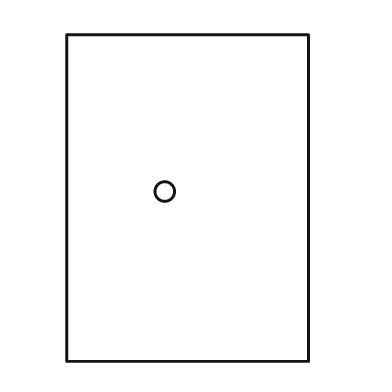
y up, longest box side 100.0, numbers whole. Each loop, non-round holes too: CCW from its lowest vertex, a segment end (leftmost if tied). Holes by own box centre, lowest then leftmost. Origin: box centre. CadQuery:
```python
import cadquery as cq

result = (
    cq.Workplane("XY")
    .moveTo(-37.0, -50.0)
    .lineTo(37.0, -50.0)
    .lineTo(37.0, 50.0)
    .lineTo(-37.0, 50.0)
    .close()
    .moveTo(-7.0, 2.0)
    .circle(3.0)
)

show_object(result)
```